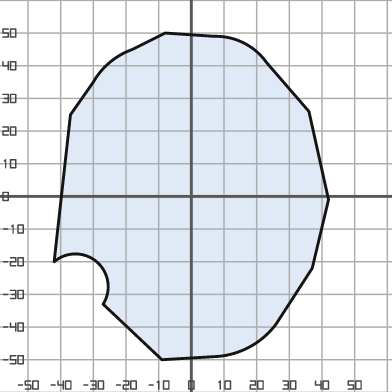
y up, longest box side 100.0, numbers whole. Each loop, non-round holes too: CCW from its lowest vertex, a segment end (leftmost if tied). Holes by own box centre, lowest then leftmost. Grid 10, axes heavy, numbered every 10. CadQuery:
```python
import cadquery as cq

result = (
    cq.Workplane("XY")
    .moveTo(-9.0, -50.0)
    .lineTo(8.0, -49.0)
    .threePointArc((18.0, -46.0), (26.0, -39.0))
    .lineTo(37.0, -22.0)
    .lineTo(42.0, -1.0)
    .lineTo(36.0, 26.0)
    .lineTo(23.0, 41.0)
    .threePointArc((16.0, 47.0), (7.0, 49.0))
    .lineTo(-8.0, 50.0)
    .lineTo(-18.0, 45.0)
    .threePointArc((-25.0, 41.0), (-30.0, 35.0))
    .lineTo(-37.0, 25.0)
    .lineTo(-42.0, -20.0)
    .threePointArc((-29.0, -20.0), (-27.0, -33.0))
    .close()
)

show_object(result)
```